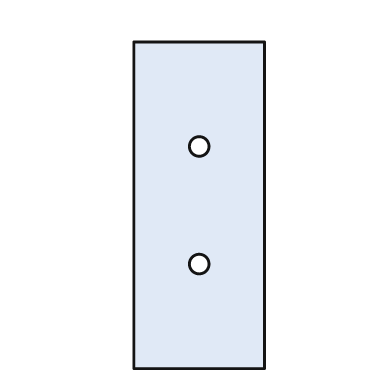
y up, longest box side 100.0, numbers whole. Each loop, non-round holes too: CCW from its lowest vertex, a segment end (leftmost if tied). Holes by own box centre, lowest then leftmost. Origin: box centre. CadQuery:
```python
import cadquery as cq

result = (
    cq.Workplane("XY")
    .moveTo(-20.0, -50.0)
    .lineTo(20.0, -50.0)
    .lineTo(20.0, 50.0)
    .lineTo(-20.0, 50.0)
    .close()
    .moveTo(0.0, -18.0)
    .circle(3.0)
    .moveTo(0.0, 18.0)
    .circle(3.0)
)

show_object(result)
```